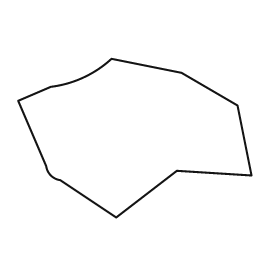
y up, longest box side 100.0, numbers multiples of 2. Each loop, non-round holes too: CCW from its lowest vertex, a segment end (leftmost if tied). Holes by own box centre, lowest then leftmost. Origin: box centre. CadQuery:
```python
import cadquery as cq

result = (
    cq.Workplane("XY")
    .moveTo(-8.0, -34.0)
    .lineTo(18.0, -14.0)
    .lineTo(50.0, -16.0)
    .lineTo(44.0, 14.0)
    .lineTo(20.0, 28.0)
    .lineTo(-10.0, 34.0)
    .threePointArc((-22.0, 26.0), (-36.0, 22.0))
    .lineTo(-50.0, 16.0)
    .lineTo(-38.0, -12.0)
    .threePointArc((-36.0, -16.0), (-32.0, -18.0))
    .close()
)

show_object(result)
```